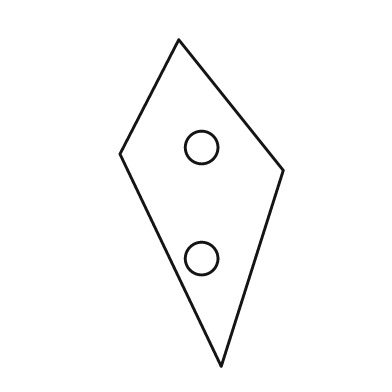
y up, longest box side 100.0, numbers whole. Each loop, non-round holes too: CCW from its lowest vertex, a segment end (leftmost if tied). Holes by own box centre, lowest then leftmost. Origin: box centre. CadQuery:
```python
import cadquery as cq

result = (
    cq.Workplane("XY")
    .moveTo(6.0, -50.0)
    .lineTo(25.0, 10.0)
    .lineTo(-7.0, 50.0)
    .lineTo(-25.0, 15.0)
    .close()
    .moveTo(0.0, -17.0)
    .circle(5.0)
    .moveTo(0.0, 17.0)
    .circle(5.0)
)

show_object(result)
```